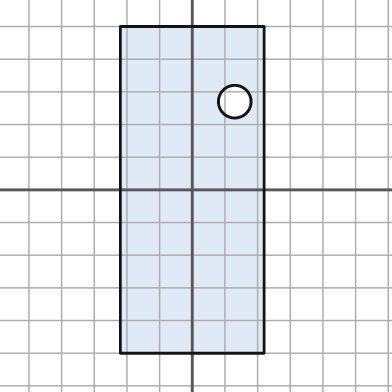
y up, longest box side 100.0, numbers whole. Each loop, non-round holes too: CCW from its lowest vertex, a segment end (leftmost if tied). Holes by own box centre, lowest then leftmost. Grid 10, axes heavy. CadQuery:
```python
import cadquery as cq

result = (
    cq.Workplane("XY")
    .moveTo(-22.0, -50.0)
    .lineTo(22.0, -50.0)
    .lineTo(22.0, 50.0)
    .lineTo(-22.0, 50.0)
    .close()
    .moveTo(13.0, 27.0)
    .circle(5.0)
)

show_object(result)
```